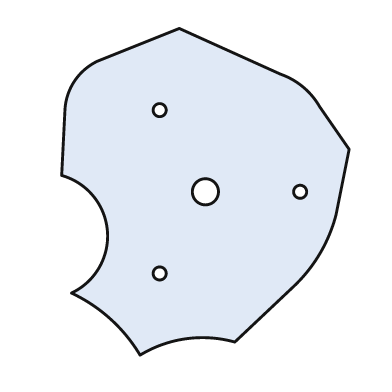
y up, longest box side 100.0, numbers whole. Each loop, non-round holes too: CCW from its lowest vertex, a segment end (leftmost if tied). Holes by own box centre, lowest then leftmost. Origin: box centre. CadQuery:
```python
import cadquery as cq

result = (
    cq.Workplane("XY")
    .moveTo(-20.0, -50.0)
    .threePointArc((-6.0, -45.0), (9.0, -46.0))
    .lineTo(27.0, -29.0)
    .threePointArc((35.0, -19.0), (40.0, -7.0))
    .lineTo(44.0, 13.0)
    .lineTo(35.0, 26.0)
    .threePointArc((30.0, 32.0), (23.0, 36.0))
    .lineTo(-8.0, 50.0)
    .lineTo(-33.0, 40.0)
    .threePointArc((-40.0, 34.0), (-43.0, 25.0))
    .lineTo(-44.0, 5.0)
    .threePointArc((-30.0, -12.0), (-41.0, -31.0))
    .threePointArc((-29.0, -39.0), (-20.0, -50.0))
    .close()
    .moveTo(-14.0, -25.0)
    .circle(2.0)
    .moveTo(0.0, 0.0)
    .circle(4.0)
    .moveTo(29.0, 0.0)
    .circle(2.0)
    .moveTo(-14.0, 25.0)
    .circle(2.0)
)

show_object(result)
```